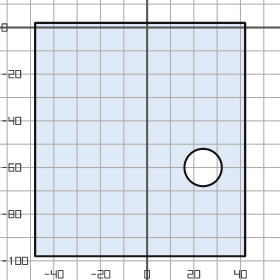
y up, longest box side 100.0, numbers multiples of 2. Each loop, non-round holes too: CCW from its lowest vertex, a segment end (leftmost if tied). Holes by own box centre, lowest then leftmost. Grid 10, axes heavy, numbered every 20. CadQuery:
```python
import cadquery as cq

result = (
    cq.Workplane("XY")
    .moveTo(-48.0, -98.0)
    .lineTo(42.0, -98.0)
    .lineTo(42.0, 2.0)
    .lineTo(-48.0, 2.0)
    .close()
    .moveTo(24.0, -60.0)
    .circle(8.0)
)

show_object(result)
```